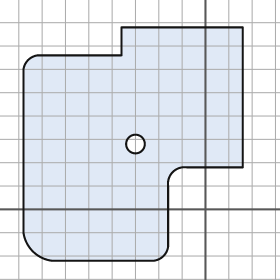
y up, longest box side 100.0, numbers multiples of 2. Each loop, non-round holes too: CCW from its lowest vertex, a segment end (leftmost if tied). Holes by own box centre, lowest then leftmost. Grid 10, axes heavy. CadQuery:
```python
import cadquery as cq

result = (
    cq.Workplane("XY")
    .moveTo(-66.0, -22.0)
    .lineTo(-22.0, -22.0)
    .threePointArc((-18.0, -20.0), (-16.0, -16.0))
    .lineTo(-16.0, 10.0)
    .threePointArc((-14.0, 16.0), (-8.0, 18.0))
    .lineTo(16.0, 18.0)
    .lineTo(16.0, 78.0)
    .lineTo(-36.0, 78.0)
    .lineTo(-36.0, 66.0)
    .lineTo(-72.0, 66.0)
    .threePointArc((-76.0, 64.0), (-78.0, 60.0))
    .lineTo(-78.0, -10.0)
    .threePointArc((-74.0, -18.0), (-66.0, -22.0))
    .close()
    .moveTo(-30.0, 28.0)
    .circle(4.0)
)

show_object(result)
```